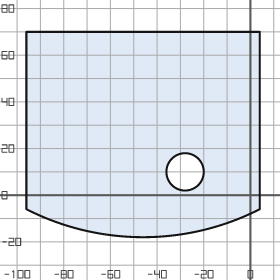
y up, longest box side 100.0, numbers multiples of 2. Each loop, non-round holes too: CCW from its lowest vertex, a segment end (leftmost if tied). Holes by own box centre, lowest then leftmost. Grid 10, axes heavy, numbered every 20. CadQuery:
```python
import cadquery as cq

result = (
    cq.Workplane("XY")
    .moveTo(-96.0, -6.0)
    .threePointArc((-46.0, -18.0), (4.0, -6.0))
    .lineTo(4.0, 70.0)
    .lineTo(-96.0, 70.0)
    .close()
    .moveTo(-28.0, 10.0)
    .circle(8.0)
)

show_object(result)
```